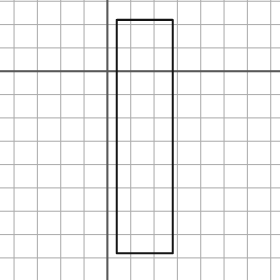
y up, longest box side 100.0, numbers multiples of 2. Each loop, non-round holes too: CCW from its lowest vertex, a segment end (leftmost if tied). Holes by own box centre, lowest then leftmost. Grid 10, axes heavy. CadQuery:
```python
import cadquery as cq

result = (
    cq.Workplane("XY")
    .moveTo(4.0, -78.0)
    .lineTo(28.0, -78.0)
    .lineTo(28.0, 22.0)
    .lineTo(4.0, 22.0)
    .close()
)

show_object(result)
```